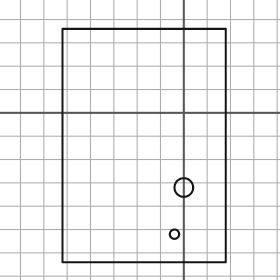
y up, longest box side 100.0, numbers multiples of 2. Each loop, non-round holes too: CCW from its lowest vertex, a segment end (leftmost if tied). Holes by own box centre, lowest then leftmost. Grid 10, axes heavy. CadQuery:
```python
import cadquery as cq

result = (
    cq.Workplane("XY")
    .moveTo(-52.0, -64.0)
    .lineTo(18.0, -64.0)
    .lineTo(18.0, 36.0)
    .lineTo(-52.0, 36.0)
    .close()
    .moveTo(-4.0, -52.0)
    .circle(2.0)
    .moveTo(0.0, -32.0)
    .circle(4.0)
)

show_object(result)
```